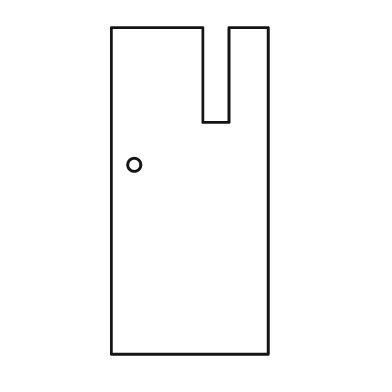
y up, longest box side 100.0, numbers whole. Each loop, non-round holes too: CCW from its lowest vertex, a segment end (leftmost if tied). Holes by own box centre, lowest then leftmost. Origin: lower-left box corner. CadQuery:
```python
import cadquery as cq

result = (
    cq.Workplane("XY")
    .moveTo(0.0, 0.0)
    .lineTo(48.0, 0.0)
    .lineTo(48.0, 100.0)
    .lineTo(36.0, 100.0)
    .lineTo(36.0, 71.0)
    .lineTo(28.0, 71.0)
    .lineTo(28.0, 100.0)
    .lineTo(0.0, 100.0)
    .close()
    .moveTo(7.0, 58.0)
    .circle(2.0)
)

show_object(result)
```